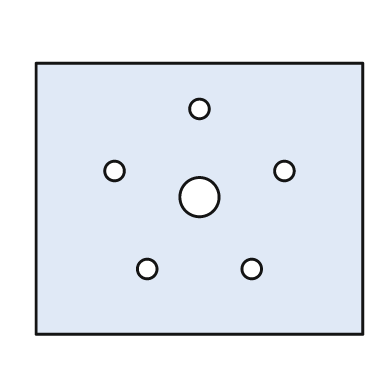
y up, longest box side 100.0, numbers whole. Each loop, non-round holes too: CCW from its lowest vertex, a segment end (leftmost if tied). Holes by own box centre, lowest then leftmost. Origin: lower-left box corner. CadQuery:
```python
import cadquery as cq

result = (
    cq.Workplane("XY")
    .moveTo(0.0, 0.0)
    .lineTo(100.0, 0.0)
    .lineTo(100.0, 83.0)
    .lineTo(0.0, 83.0)
    .close()
    .moveTo(34.0, 20.0)
    .circle(3.0)
    .moveTo(66.0, 20.0)
    .circle(3.0)
    .moveTo(50.0, 42.0)
    .circle(6.0)
    .moveTo(24.0, 50.0)
    .circle(3.0)
    .moveTo(76.0, 50.0)
    .circle(3.0)
    .moveTo(50.0, 69.0)
    .circle(3.0)
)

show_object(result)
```